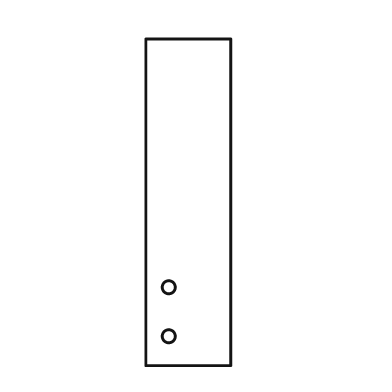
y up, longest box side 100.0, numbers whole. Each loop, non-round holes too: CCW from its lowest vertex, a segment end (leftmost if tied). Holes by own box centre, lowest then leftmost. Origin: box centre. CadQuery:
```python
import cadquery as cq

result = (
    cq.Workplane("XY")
    .moveTo(-13.0, -50.0)
    .lineTo(13.0, -50.0)
    .lineTo(13.0, 50.0)
    .lineTo(-13.0, 50.0)
    .close()
    .moveTo(-6.0, -41.0)
    .circle(2.0)
    .moveTo(-6.0, -26.0)
    .circle(2.0)
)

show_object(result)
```